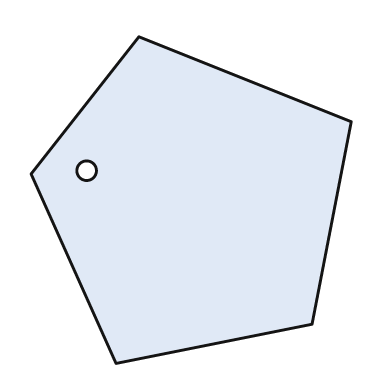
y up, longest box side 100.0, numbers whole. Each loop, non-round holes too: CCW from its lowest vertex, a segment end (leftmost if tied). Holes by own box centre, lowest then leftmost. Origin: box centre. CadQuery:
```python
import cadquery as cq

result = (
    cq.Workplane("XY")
    .moveTo(-23.0, -50.0)
    .lineTo(37.0, -38.0)
    .lineTo(49.0, 24.0)
    .lineTo(-16.0, 50.0)
    .lineTo(-49.0, 8.0)
    .close()
    .moveTo(-32.0, 9.0)
    .circle(3.0)
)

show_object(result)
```